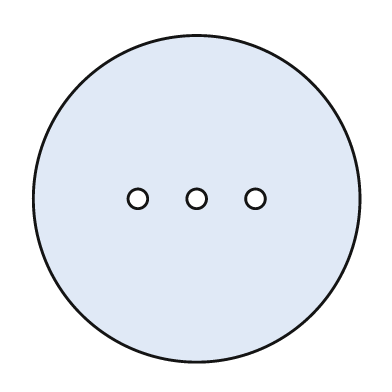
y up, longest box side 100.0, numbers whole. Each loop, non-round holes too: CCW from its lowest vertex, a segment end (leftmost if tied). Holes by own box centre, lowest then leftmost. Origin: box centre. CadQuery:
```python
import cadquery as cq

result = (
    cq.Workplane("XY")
    .moveTo(0.0, 0.0)
    .circle(50.0)
    .moveTo(-18.0, 0.0)
    .circle(3.0)
    .moveTo(0.0, 0.0)
    .circle(3.0)
    .moveTo(18.0, 0.0)
    .circle(3.0)
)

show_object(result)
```